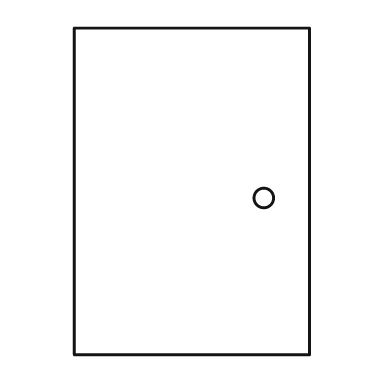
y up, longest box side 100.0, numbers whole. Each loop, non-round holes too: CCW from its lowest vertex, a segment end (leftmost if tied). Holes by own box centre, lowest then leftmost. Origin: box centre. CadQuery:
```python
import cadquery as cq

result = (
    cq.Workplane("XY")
    .moveTo(-36.0, -50.0)
    .lineTo(36.0, -50.0)
    .lineTo(36.0, 50.0)
    .lineTo(-36.0, 50.0)
    .close()
    .moveTo(22.0, -2.0)
    .circle(3.0)
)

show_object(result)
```